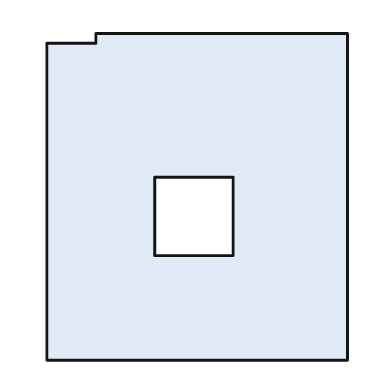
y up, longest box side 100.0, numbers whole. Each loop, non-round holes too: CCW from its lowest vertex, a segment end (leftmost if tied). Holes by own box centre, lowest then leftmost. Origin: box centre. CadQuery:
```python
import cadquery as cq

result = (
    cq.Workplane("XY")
    .moveTo(-46.0, -50.0)
    .lineTo(46.0, -50.0)
    .lineTo(46.0, 50.0)
    .lineTo(-31.0, 50.0)
    .lineTo(-31.0, 47.0)
    .lineTo(-46.0, 47.0)
    .close()
    .moveTo(-13.0, -18.0)
    .lineTo(11.0, -18.0)
    .lineTo(11.0, 6.0)
    .lineTo(-13.0, 6.0)
    .close()
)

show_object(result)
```